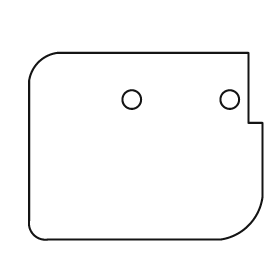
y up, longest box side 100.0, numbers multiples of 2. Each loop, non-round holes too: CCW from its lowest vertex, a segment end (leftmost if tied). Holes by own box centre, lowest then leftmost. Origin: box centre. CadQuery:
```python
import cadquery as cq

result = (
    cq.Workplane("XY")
    .moveTo(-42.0, -40.0)
    .lineTo(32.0, -40.0)
    .threePointArc((44.0, -34.0), (50.0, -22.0))
    .lineTo(50.0, 10.0)
    .lineTo(44.0, 10.0)
    .lineTo(44.0, 40.0)
    .lineTo(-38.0, 40.0)
    .threePointArc((-46.0, 36.0), (-50.0, 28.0))
    .lineTo(-50.0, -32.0)
    .threePointArc((-48.0, -38.0), (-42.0, -40.0))
    .close()
    .moveTo(-6.0, 20.0)
    .circle(4.0)
    .moveTo(36.0, 20.0)
    .circle(4.0)
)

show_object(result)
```